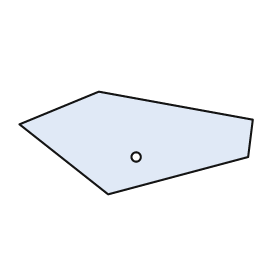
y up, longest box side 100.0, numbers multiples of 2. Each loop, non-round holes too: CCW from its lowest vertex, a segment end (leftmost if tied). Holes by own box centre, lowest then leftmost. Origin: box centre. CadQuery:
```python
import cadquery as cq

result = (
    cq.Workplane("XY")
    .moveTo(-12.0, -22.0)
    .lineTo(48.0, -6.0)
    .lineTo(50.0, 10.0)
    .lineTo(-16.0, 22.0)
    .lineTo(-50.0, 8.0)
    .close()
    .moveTo(0.0, -6.0)
    .circle(2.0)
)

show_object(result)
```